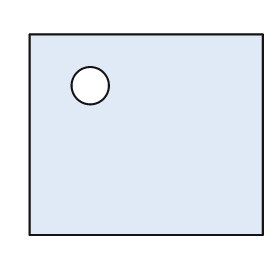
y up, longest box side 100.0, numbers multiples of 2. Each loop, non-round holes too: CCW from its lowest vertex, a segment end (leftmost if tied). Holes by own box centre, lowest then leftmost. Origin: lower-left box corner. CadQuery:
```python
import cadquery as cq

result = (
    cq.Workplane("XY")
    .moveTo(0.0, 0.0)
    .lineTo(100.0, 0.0)
    .lineTo(100.0, 86.0)
    .lineTo(0.0, 86.0)
    .close()
    .moveTo(26.0, 64.0)
    .circle(8.0)
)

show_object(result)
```